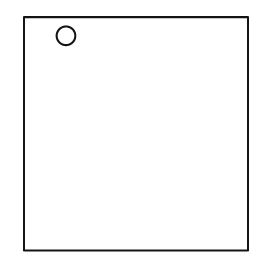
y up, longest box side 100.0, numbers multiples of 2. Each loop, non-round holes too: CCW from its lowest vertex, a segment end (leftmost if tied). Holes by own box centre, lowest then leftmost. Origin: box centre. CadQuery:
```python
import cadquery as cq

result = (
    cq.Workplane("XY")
    .moveTo(-48.0, -50.0)
    .lineTo(48.0, -50.0)
    .lineTo(48.0, 50.0)
    .lineTo(-48.0, 50.0)
    .close()
    .moveTo(-30.0, 42.0)
    .circle(4.0)
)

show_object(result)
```